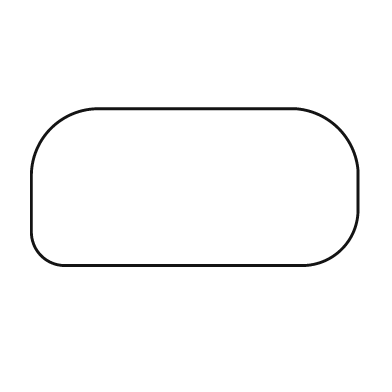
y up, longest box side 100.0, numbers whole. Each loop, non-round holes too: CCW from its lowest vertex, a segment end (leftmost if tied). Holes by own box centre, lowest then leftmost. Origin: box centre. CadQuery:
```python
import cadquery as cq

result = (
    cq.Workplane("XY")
    .moveTo(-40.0, -24.0)
    .lineTo(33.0, -24.0)
    .threePointArc((45.0, -19.0), (50.0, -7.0))
    .lineTo(50.0, 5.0)
    .threePointArc((44.0, 18.0), (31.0, 24.0))
    .lineTo(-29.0, 24.0)
    .threePointArc((-44.0, 18.0), (-50.0, 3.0))
    .lineTo(-50.0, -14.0)
    .threePointArc((-47.0, -21.0), (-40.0, -24.0))
    .close()
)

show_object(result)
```